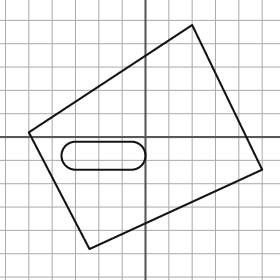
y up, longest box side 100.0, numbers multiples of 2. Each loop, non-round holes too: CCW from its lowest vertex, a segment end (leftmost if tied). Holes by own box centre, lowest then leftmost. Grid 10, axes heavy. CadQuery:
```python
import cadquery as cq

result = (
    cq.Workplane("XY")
    .moveTo(-24.0, -48.0)
    .lineTo(50.0, -14.0)
    .lineTo(20.0, 48.0)
    .lineTo(-50.0, 2.0)
    .close()
    .moveTo(-30.0, -14.0)
    .lineTo(-6.0, -14.0)
    .threePointArc((0.0, -8.0), (-6.0, -2.0))
    .lineTo(-30.0, -2.0)
    .threePointArc((-36.0, -8.0), (-30.0, -14.0))
    .close()
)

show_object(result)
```